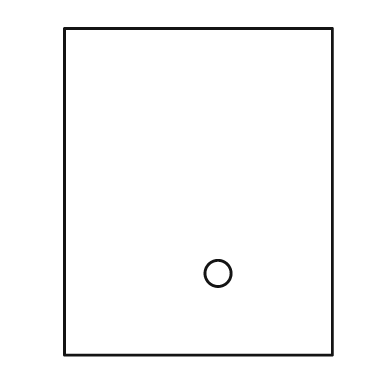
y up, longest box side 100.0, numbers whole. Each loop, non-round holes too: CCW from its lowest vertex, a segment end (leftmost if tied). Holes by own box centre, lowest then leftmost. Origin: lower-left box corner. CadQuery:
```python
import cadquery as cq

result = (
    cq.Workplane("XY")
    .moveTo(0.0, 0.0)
    .lineTo(82.0, 0.0)
    .lineTo(82.0, 100.0)
    .lineTo(0.0, 100.0)
    .close()
    .moveTo(47.0, 25.0)
    .circle(4.0)
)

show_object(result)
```